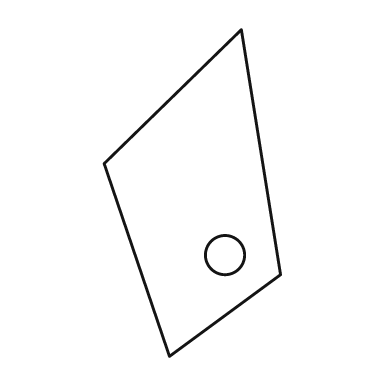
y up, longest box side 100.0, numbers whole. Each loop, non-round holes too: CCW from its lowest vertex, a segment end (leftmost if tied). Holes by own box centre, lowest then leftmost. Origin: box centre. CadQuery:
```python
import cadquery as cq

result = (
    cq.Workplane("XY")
    .moveTo(-7.0, -50.0)
    .lineTo(27.0, -25.0)
    .lineTo(15.0, 50.0)
    .lineTo(-27.0, 9.0)
    .close()
    .moveTo(10.0, -19.0)
    .circle(6.0)
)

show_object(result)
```